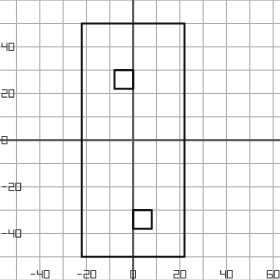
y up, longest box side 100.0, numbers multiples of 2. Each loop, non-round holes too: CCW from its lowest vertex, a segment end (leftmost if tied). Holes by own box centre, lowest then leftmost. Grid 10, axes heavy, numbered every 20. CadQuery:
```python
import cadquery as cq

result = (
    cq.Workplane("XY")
    .moveTo(-22.0, -50.0)
    .lineTo(22.0, -50.0)
    .lineTo(22.0, 50.0)
    .lineTo(-22.0, 50.0)
    .close()
    .moveTo(0.0, -38.0)
    .lineTo(8.0, -38.0)
    .lineTo(8.0, -30.0)
    .lineTo(0.0, -30.0)
    .close()
    .moveTo(-8.0, 22.0)
    .lineTo(0.0, 22.0)
    .lineTo(0.0, 30.0)
    .lineTo(-8.0, 30.0)
    .close()
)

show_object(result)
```